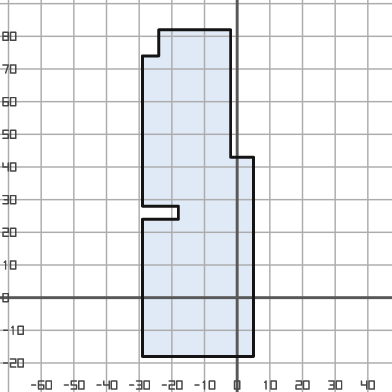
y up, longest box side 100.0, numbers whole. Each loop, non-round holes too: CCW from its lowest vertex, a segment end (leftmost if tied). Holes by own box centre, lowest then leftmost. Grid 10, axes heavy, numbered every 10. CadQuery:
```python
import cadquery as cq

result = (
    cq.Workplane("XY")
    .moveTo(-29.0, -18.0)
    .lineTo(5.0, -18.0)
    .lineTo(5.0, 43.0)
    .lineTo(-2.0, 43.0)
    .lineTo(-2.0, 82.0)
    .lineTo(-24.0, 82.0)
    .lineTo(-24.0, 74.0)
    .lineTo(-29.0, 74.0)
    .lineTo(-29.0, 28.0)
    .lineTo(-18.0, 28.0)
    .lineTo(-18.0, 24.0)
    .lineTo(-29.0, 24.0)
    .close()
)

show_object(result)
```